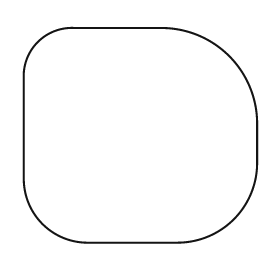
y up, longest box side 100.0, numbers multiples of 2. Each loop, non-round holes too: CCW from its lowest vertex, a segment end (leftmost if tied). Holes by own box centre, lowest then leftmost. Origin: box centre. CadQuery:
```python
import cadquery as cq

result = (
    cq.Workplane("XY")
    .moveTo(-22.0, -46.0)
    .lineTo(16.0, -46.0)
    .threePointArc((40.0, -36.0), (50.0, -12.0))
    .lineTo(50.0, 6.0)
    .threePointArc((38.0, 34.0), (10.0, 46.0))
    .lineTo(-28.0, 46.0)
    .threePointArc((-44.0, 40.0), (-50.0, 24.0))
    .lineTo(-50.0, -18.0)
    .threePointArc((-42.0, -38.0), (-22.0, -46.0))
    .close()
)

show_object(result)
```